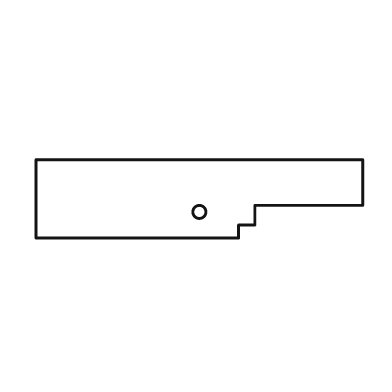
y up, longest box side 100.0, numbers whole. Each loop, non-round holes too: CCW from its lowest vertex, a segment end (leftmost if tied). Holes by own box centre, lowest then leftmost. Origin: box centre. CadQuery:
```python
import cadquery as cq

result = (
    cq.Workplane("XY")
    .moveTo(-50.0, -12.0)
    .lineTo(12.0, -12.0)
    .lineTo(12.0, -8.0)
    .lineTo(17.0, -8.0)
    .lineTo(17.0, -2.0)
    .lineTo(50.0, -2.0)
    .lineTo(50.0, 12.0)
    .lineTo(-50.0, 12.0)
    .close()
    .moveTo(0.0, -4.0)
    .circle(2.0)
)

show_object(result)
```